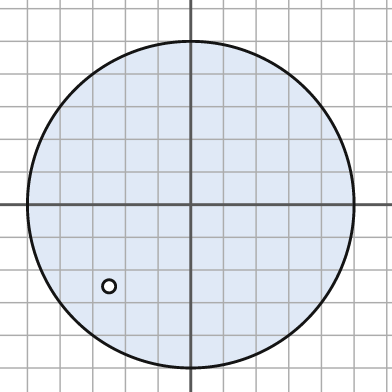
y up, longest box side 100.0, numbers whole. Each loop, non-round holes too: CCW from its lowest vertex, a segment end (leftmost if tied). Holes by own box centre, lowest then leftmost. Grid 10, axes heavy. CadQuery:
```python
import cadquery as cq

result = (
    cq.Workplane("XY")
    .moveTo(0.0, 0.0)
    .circle(50.0)
    .moveTo(-25.0, -25.0)
    .circle(2.0)
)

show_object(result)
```